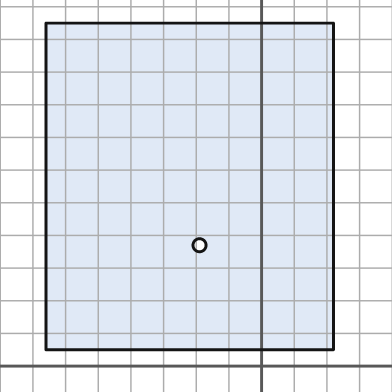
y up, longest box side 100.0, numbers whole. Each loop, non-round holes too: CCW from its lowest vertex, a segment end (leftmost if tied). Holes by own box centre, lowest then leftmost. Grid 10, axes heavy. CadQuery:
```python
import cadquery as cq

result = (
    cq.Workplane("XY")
    .moveTo(-66.0, 5.0)
    .lineTo(22.0, 5.0)
    .lineTo(22.0, 105.0)
    .lineTo(-66.0, 105.0)
    .close()
    .moveTo(-19.0, 37.0)
    .circle(2.0)
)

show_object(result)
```